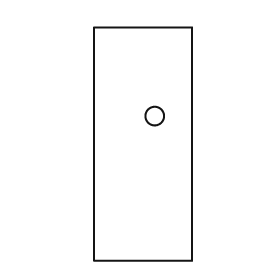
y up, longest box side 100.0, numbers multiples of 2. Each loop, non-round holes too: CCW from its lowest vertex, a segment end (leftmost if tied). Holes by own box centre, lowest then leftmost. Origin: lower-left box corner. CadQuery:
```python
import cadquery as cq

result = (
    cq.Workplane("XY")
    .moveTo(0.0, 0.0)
    .lineTo(42.0, 0.0)
    .lineTo(42.0, 100.0)
    .lineTo(0.0, 100.0)
    .close()
    .moveTo(26.0, 62.0)
    .circle(4.0)
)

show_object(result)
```